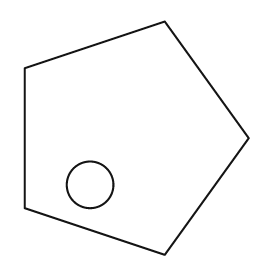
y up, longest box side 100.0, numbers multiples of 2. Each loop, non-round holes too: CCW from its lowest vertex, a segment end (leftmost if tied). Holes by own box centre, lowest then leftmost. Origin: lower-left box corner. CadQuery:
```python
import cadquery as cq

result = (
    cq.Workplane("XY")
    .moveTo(60.0, 0.0)
    .lineTo(96.0, 50.0)
    .lineTo(60.0, 100.0)
    .lineTo(0.0, 80.0)
    .lineTo(0.0, 20.0)
    .close()
    .moveTo(28.0, 30.0)
    .circle(10.0)
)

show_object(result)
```